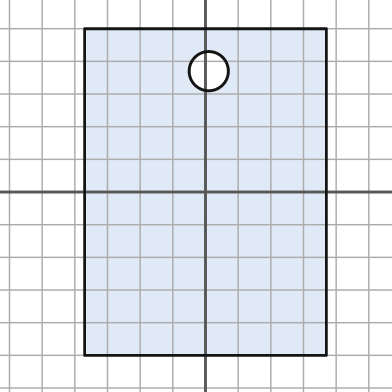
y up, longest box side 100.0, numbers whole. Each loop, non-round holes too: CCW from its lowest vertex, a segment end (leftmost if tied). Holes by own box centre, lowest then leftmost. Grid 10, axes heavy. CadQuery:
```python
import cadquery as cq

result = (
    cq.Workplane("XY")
    .moveTo(-37.0, -50.0)
    .lineTo(37.0, -50.0)
    .lineTo(37.0, 50.0)
    .lineTo(-37.0, 50.0)
    .close()
    .moveTo(1.0, 37.0)
    .circle(6.0)
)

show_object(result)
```